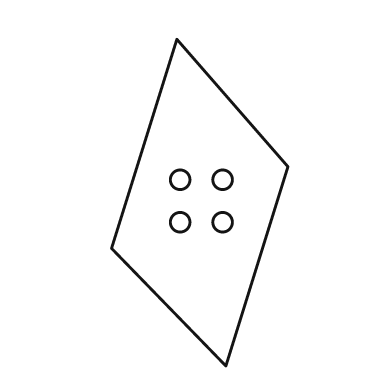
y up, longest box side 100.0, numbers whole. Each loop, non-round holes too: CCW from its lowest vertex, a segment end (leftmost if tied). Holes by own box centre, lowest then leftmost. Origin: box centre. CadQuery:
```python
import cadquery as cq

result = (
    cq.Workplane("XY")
    .moveTo(8.0, -50.0)
    .lineTo(27.0, 11.0)
    .lineTo(-7.0, 50.0)
    .lineTo(-27.0, -14.0)
    .close()
    .moveTo(-6.0, -6.0)
    .circle(3.0)
    .moveTo(7.0, -6.0)
    .circle(3.0)
    .moveTo(-6.0, 7.0)
    .circle(3.0)
    .moveTo(7.0, 7.0)
    .circle(3.0)
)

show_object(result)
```